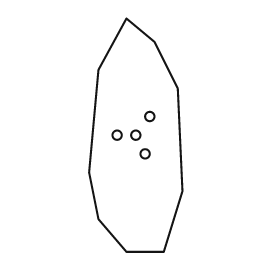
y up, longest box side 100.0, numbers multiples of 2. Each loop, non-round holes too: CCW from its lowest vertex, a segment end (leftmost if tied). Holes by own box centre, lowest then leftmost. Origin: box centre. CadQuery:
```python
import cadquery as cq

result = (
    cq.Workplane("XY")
    .moveTo(-4.0, -50.0)
    .lineTo(12.0, -50.0)
    .lineTo(20.0, -24.0)
    .lineTo(18.0, 20.0)
    .lineTo(8.0, 40.0)
    .lineTo(-4.0, 50.0)
    .lineTo(-16.0, 28.0)
    .lineTo(-20.0, -16.0)
    .lineTo(-16.0, -36.0)
    .close()
    .moveTo(4.0, -8.0)
    .circle(2.0)
    .moveTo(-8.0, 0.0)
    .circle(2.0)
    .moveTo(0.0, 0.0)
    .circle(2.0)
    .moveTo(6.0, 8.0)
    .circle(2.0)
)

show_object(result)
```